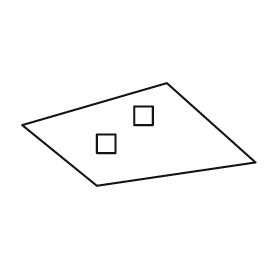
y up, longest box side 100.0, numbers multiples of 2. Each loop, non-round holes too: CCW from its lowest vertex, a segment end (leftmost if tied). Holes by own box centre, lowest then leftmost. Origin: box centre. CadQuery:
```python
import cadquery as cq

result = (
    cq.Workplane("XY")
    .moveTo(-18.0, -22.0)
    .lineTo(50.0, -12.0)
    .lineTo(12.0, 22.0)
    .lineTo(-50.0, 4.0)
    .close()
    .moveTo(-18.0, -8.0)
    .lineTo(-10.0, -8.0)
    .lineTo(-10.0, 0.0)
    .lineTo(-18.0, 0.0)
    .close()
    .moveTo(-2.0, 4.0)
    .lineTo(6.0, 4.0)
    .lineTo(6.0, 12.0)
    .lineTo(-2.0, 12.0)
    .close()
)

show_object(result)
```